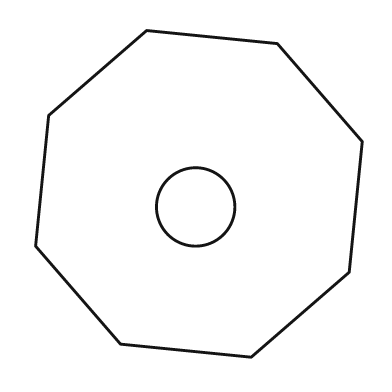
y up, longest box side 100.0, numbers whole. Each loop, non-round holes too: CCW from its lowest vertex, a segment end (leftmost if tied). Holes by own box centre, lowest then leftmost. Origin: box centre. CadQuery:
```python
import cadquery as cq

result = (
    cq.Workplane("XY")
    .moveTo(16.0, -50.0)
    .lineTo(46.0, -24.0)
    .lineTo(50.0, 16.0)
    .lineTo(24.0, 46.0)
    .lineTo(-16.0, 50.0)
    .lineTo(-46.0, 24.0)
    .lineTo(-50.0, -16.0)
    .lineTo(-24.0, -46.0)
    .close()
    .moveTo(-1.0, -4.0)
    .circle(12.0)
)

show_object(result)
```